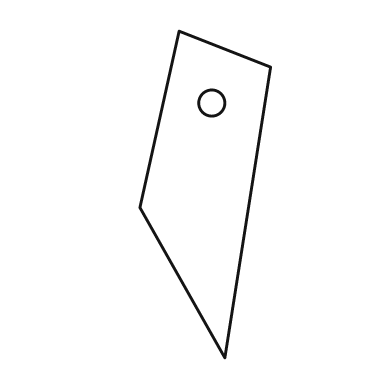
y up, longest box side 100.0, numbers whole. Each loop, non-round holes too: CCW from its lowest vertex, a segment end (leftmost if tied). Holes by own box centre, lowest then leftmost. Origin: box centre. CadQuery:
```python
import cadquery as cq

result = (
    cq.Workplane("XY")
    .moveTo(6.0, -50.0)
    .lineTo(20.0, 39.0)
    .lineTo(-8.0, 50.0)
    .lineTo(-20.0, -4.0)
    .close()
    .moveTo(2.0, 28.0)
    .circle(4.0)
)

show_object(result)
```